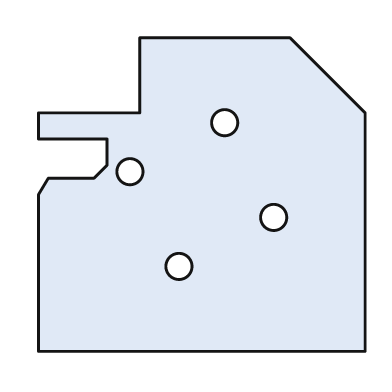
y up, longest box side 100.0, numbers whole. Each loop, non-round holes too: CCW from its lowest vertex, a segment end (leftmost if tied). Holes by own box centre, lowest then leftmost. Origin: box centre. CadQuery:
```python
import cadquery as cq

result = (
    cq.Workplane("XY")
    .moveTo(-50.0, -48.0)
    .lineTo(50.0, -48.0)
    .lineTo(50.0, 25.0)
    .lineTo(27.0, 48.0)
    .lineTo(-19.0, 48.0)
    .lineTo(-19.0, 25.0)
    .lineTo(-50.0, 25.0)
    .lineTo(-50.0, 17.0)
    .lineTo(-29.0, 17.0)
    .lineTo(-29.0, 9.0)
    .lineTo(-33.0, 5.0)
    .lineTo(-47.0, 5.0)
    .lineTo(-50.0, 0.0)
    .close()
    .moveTo(-7.0, -22.0)
    .circle(4.0)
    .moveTo(22.0, -7.0)
    .circle(4.0)
    .moveTo(-22.0, 7.0)
    .circle(4.0)
    .moveTo(7.0, 22.0)
    .circle(4.0)
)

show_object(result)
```